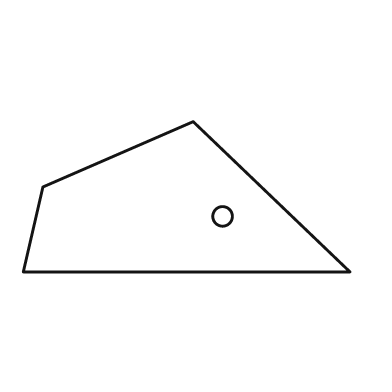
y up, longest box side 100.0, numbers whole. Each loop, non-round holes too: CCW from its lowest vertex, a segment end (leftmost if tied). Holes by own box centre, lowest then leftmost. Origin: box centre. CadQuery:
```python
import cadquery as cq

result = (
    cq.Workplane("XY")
    .moveTo(-50.0, -23.0)
    .lineTo(50.0, -23.0)
    .lineTo(2.0, 23.0)
    .lineTo(-44.0, 3.0)
    .close()
    .moveTo(11.0, -6.0)
    .circle(3.0)
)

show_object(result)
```